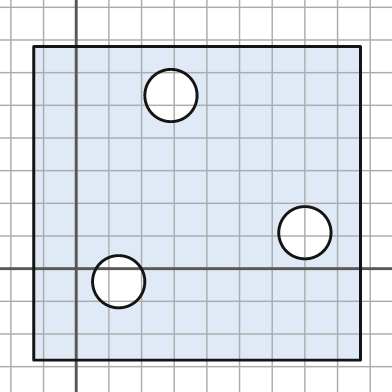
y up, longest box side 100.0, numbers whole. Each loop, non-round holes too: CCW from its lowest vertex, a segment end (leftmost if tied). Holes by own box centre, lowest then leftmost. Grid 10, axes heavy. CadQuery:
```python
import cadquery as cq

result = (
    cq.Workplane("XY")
    .moveTo(-13.0, -28.0)
    .lineTo(87.0, -28.0)
    .lineTo(87.0, 68.0)
    .lineTo(-13.0, 68.0)
    .close()
    .moveTo(13.0, -4.0)
    .circle(8.0)
    .moveTo(70.0, 11.0)
    .circle(8.0)
    .moveTo(29.0, 53.0)
    .circle(8.0)
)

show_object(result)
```